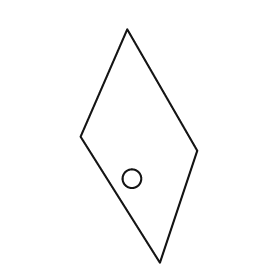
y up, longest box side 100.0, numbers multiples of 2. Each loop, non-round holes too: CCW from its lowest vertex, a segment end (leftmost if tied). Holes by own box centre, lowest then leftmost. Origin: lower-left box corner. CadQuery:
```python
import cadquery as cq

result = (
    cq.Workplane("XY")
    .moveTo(34.0, 0.0)
    .lineTo(50.0, 48.0)
    .lineTo(20.0, 100.0)
    .lineTo(0.0, 54.0)
    .close()
    .moveTo(22.0, 36.0)
    .circle(4.0)
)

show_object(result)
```